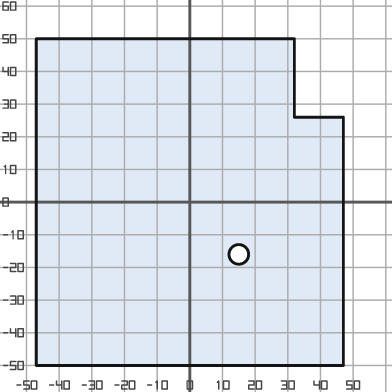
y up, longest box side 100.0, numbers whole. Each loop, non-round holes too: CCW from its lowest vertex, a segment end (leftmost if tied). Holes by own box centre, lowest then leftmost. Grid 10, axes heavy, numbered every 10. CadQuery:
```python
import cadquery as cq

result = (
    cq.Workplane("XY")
    .moveTo(-47.0, -50.0)
    .lineTo(47.0, -50.0)
    .lineTo(47.0, 26.0)
    .lineTo(32.0, 26.0)
    .lineTo(32.0, 50.0)
    .lineTo(-47.0, 50.0)
    .close()
    .moveTo(15.0, -16.0)
    .circle(3.0)
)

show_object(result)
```